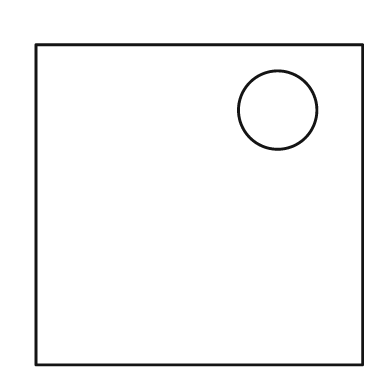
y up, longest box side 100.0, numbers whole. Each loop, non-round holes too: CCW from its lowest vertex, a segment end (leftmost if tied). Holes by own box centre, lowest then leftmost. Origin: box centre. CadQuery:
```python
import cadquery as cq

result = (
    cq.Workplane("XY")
    .moveTo(-50.0, -49.0)
    .lineTo(50.0, -49.0)
    .lineTo(50.0, 49.0)
    .lineTo(-50.0, 49.0)
    .close()
    .moveTo(24.0, 29.0)
    .circle(12.0)
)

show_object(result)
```